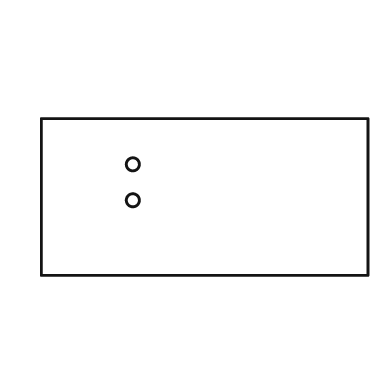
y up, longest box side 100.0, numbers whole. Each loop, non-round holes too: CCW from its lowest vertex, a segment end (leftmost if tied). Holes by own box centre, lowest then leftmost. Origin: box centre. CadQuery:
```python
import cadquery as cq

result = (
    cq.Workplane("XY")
    .moveTo(-50.0, -24.0)
    .lineTo(50.0, -24.0)
    .lineTo(50.0, 24.0)
    .lineTo(-50.0, 24.0)
    .close()
    .moveTo(-22.0, -1.0)
    .circle(2.0)
    .moveTo(-22.0, 10.0)
    .circle(2.0)
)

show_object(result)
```